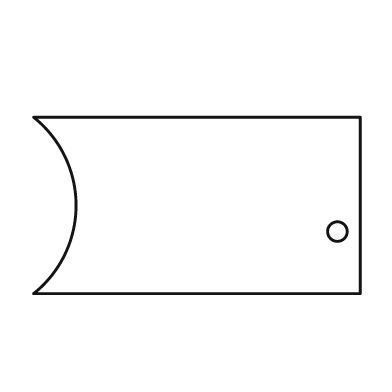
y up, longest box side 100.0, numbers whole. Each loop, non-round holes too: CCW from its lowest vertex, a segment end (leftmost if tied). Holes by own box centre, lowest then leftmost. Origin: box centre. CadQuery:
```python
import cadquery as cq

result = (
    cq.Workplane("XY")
    .moveTo(-50.0, -27.0)
    .lineTo(50.0, -27.0)
    .lineTo(50.0, 27.0)
    .lineTo(-50.0, 27.0)
    .threePointArc((-37.0, 0.0), (-50.0, -27.0))
    .close()
    .moveTo(43.0, -8.0)
    .circle(3.0)
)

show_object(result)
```